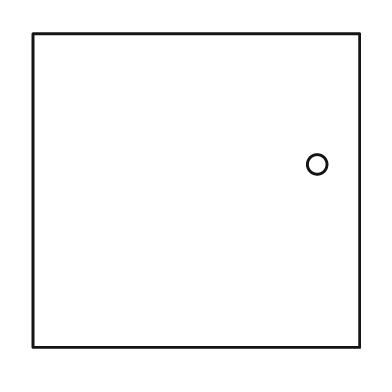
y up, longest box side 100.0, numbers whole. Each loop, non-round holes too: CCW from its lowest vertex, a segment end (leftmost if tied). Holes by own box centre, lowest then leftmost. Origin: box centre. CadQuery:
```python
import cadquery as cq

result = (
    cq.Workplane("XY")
    .moveTo(-50.0, -48.0)
    .lineTo(50.0, -48.0)
    .lineTo(50.0, 48.0)
    .lineTo(-50.0, 48.0)
    .close()
    .moveTo(37.0, 8.0)
    .circle(3.0)
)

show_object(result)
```